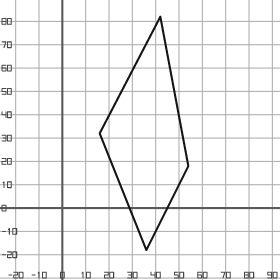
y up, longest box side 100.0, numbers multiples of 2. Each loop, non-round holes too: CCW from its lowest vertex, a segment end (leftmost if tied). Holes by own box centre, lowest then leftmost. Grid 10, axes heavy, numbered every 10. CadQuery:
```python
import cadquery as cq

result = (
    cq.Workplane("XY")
    .moveTo(36.0, -18.0)
    .lineTo(54.0, 18.0)
    .lineTo(42.0, 82.0)
    .lineTo(16.0, 32.0)
    .close()
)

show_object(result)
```